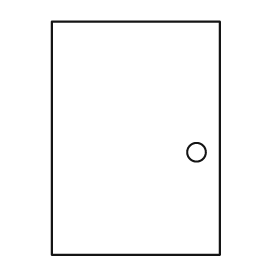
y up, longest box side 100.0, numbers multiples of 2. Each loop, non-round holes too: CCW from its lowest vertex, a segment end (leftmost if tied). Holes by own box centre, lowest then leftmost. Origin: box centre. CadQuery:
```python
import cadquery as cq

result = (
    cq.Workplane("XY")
    .moveTo(-36.0, -50.0)
    .lineTo(36.0, -50.0)
    .lineTo(36.0, 50.0)
    .lineTo(-36.0, 50.0)
    .close()
    .moveTo(26.0, -6.0)
    .circle(4.0)
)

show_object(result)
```